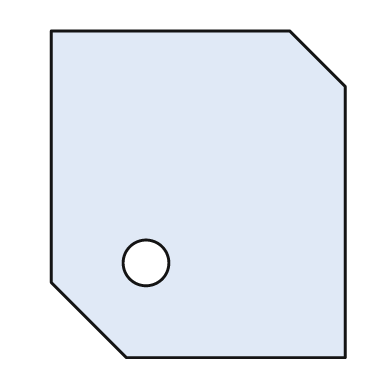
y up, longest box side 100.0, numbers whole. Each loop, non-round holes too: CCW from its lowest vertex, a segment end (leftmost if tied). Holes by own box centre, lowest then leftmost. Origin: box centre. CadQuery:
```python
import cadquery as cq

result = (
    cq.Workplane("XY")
    .moveTo(-22.0, -50.0)
    .lineTo(45.0, -50.0)
    .lineTo(45.0, 33.0)
    .lineTo(28.0, 50.0)
    .lineTo(-45.0, 50.0)
    .lineTo(-45.0, -27.0)
    .close()
    .moveTo(-16.0, -21.0)
    .circle(7.0)
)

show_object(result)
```